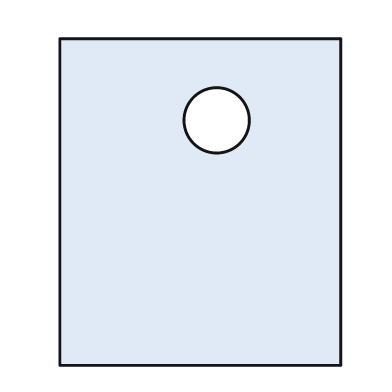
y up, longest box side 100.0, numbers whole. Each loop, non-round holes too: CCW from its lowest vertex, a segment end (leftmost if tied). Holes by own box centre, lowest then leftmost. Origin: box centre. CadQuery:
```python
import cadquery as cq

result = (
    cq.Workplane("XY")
    .moveTo(-43.0, -50.0)
    .lineTo(43.0, -50.0)
    .lineTo(43.0, 50.0)
    .lineTo(-43.0, 50.0)
    .close()
    .moveTo(5.0, 25.0)
    .circle(10.0)
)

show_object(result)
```